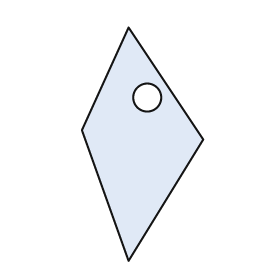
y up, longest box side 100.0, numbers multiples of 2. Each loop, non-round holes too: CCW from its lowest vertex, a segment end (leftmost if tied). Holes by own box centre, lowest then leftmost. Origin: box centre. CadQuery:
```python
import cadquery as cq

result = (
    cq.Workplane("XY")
    .moveTo(-6.0, -50.0)
    .lineTo(26.0, 2.0)
    .lineTo(-6.0, 50.0)
    .lineTo(-26.0, 6.0)
    .close()
    .moveTo(2.0, 20.0)
    .circle(6.0)
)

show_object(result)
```